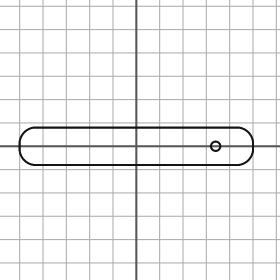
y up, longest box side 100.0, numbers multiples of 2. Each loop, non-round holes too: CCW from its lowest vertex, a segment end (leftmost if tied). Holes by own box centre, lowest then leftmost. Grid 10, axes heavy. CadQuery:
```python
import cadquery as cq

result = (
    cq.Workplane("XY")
    .moveTo(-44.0, -8.0)
    .lineTo(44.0, -8.0)
    .threePointArc((48.0, -6.0), (50.0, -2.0))
    .lineTo(50.0, 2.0)
    .threePointArc((48.0, 6.0), (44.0, 8.0))
    .lineTo(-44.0, 8.0)
    .threePointArc((-48.0, 6.0), (-50.0, 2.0))
    .lineTo(-50.0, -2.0)
    .threePointArc((-48.0, -6.0), (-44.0, -8.0))
    .close()
    .moveTo(34.0, 0.0)
    .circle(2.0)
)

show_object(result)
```